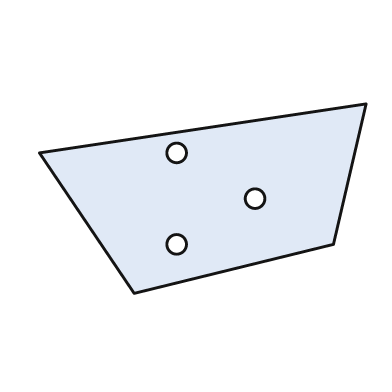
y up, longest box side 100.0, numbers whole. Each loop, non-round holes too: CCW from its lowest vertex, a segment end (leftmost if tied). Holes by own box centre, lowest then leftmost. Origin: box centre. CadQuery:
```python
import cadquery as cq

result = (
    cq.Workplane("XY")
    .moveTo(-21.0, -29.0)
    .lineTo(40.0, -14.0)
    .lineTo(50.0, 29.0)
    .lineTo(-50.0, 14.0)
    .close()
    .moveTo(-8.0, -14.0)
    .circle(3.0)
    .moveTo(16.0, 0.0)
    .circle(3.0)
    .moveTo(-8.0, 14.0)
    .circle(3.0)
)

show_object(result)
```